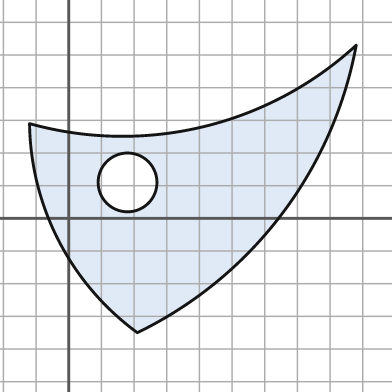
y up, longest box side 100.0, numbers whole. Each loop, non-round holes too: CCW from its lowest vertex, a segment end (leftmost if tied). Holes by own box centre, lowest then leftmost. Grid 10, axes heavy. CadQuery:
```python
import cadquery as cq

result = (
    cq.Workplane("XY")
    .moveTo(21.0, -35.0)
    .threePointArc((65.0, 1.0), (88.0, 53.0))
    .threePointArc((41.0, 28.0), (-12.0, 29.0))
    .threePointArc((-3.0, -7.0), (21.0, -35.0))
    .close()
    .moveTo(18.0, 11.0)
    .circle(9.0)
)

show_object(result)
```